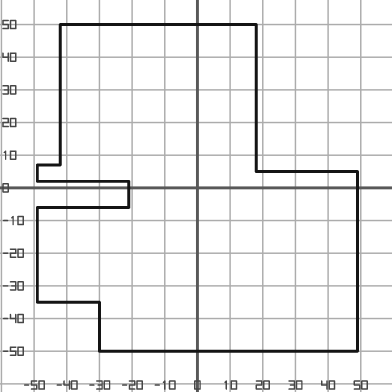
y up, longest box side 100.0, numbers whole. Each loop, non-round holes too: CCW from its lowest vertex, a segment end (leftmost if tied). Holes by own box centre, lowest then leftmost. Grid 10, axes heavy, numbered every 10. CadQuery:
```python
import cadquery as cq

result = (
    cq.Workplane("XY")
    .moveTo(-30.0, -50.0)
    .lineTo(49.0, -50.0)
    .lineTo(49.0, 5.0)
    .lineTo(18.0, 5.0)
    .lineTo(18.0, 50.0)
    .lineTo(-42.0, 50.0)
    .lineTo(-42.0, 7.0)
    .lineTo(-49.0, 7.0)
    .lineTo(-49.0, 2.0)
    .lineTo(-21.0, 2.0)
    .lineTo(-21.0, -6.0)
    .lineTo(-49.0, -6.0)
    .lineTo(-49.0, -35.0)
    .lineTo(-30.0, -35.0)
    .close()
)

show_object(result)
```